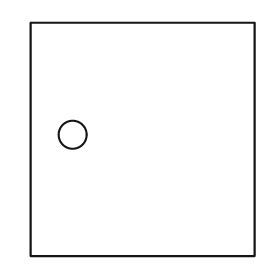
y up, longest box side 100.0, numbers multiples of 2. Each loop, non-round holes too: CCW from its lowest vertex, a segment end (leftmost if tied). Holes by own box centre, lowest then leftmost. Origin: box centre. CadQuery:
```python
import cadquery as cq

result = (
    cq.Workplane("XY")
    .moveTo(-48.0, -50.0)
    .lineTo(48.0, -50.0)
    .lineTo(48.0, 50.0)
    .lineTo(-48.0, 50.0)
    .close()
    .moveTo(-30.0, 2.0)
    .circle(6.0)
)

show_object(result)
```